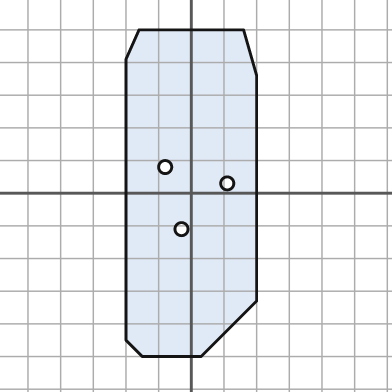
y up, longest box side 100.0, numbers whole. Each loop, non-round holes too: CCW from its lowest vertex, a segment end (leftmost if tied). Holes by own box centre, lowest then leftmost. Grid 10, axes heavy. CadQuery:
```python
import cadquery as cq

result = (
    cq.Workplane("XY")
    .moveTo(-15.0, -50.0)
    .lineTo(3.0, -50.0)
    .lineTo(20.0, -33.0)
    .lineTo(20.0, 36.0)
    .lineTo(16.0, 50.0)
    .lineTo(-16.0, 50.0)
    .lineTo(-20.0, 41.0)
    .lineTo(-20.0, -45.0)
    .close()
    .moveTo(-3.0, -11.0)
    .circle(2.0)
    .moveTo(11.0, 3.0)
    .circle(2.0)
    .moveTo(-8.0, 8.0)
    .circle(2.0)
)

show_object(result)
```